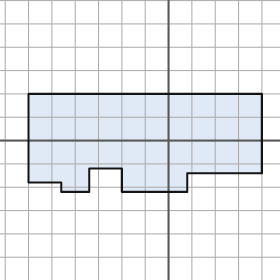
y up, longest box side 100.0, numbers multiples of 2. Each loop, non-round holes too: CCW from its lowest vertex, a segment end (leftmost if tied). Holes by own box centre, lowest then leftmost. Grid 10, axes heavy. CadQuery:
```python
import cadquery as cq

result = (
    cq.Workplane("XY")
    .moveTo(-46.0, -22.0)
    .lineTo(-34.0, -22.0)
    .lineTo(-34.0, -12.0)
    .lineTo(-20.0, -12.0)
    .lineTo(-20.0, -22.0)
    .lineTo(8.0, -22.0)
    .lineTo(8.0, -14.0)
    .lineTo(40.0, -14.0)
    .lineTo(40.0, 20.0)
    .lineTo(-60.0, 20.0)
    .lineTo(-60.0, -18.0)
    .lineTo(-46.0, -18.0)
    .close()
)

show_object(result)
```